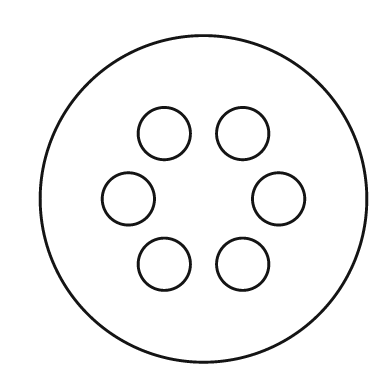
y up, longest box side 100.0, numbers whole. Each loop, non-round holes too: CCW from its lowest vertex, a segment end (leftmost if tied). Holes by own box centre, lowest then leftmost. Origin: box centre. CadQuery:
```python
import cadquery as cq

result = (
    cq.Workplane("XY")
    .moveTo(0.0, 0.0)
    .circle(50.0)
    .moveTo(-12.0, -20.0)
    .circle(8.0)
    .moveTo(12.0, -20.0)
    .circle(8.0)
    .moveTo(-23.0, 0.0)
    .circle(8.0)
    .moveTo(23.0, 0.0)
    .circle(8.0)
    .moveTo(-12.0, 20.0)
    .circle(8.0)
    .moveTo(12.0, 20.0)
    .circle(8.0)
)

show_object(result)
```